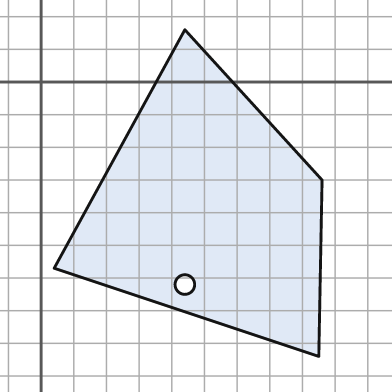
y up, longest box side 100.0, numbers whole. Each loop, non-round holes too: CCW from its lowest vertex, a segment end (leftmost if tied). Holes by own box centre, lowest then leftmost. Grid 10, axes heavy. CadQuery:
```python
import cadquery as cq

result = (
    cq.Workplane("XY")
    .moveTo(85.0, -84.0)
    .lineTo(86.0, -30.0)
    .lineTo(44.0, 16.0)
    .lineTo(4.0, -57.0)
    .close()
    .moveTo(44.0, -62.0)
    .circle(3.0)
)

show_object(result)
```